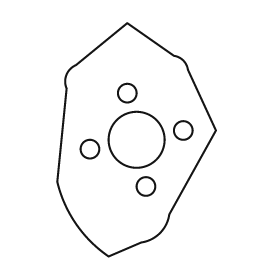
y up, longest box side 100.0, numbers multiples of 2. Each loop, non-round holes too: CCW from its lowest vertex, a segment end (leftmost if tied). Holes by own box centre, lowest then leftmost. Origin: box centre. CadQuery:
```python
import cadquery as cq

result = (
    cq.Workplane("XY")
    .moveTo(-12.0, -50.0)
    .lineTo(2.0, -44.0)
    .threePointArc((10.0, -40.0), (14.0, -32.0))
    .lineTo(34.0, 4.0)
    .lineTo(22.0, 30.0)
    .threePointArc((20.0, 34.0), (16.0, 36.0))
    .lineTo(-4.0, 50.0)
    .lineTo(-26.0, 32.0)
    .threePointArc((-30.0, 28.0), (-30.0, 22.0))
    .lineTo(-34.0, -18.0)
    .threePointArc((-26.0, -36.0), (-12.0, -50.0))
    .close()
    .moveTo(4.0, -20.0)
    .circle(4.0)
    .moveTo(-20.0, -4.0)
    .circle(4.0)
    .moveTo(0.0, 0.0)
    .circle(12.0)
    .moveTo(20.0, 4.0)
    .circle(4.0)
    .moveTo(-4.0, 20.0)
    .circle(4.0)
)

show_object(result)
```